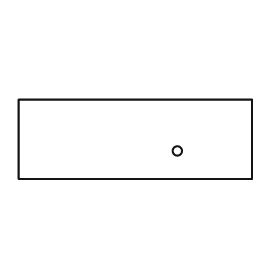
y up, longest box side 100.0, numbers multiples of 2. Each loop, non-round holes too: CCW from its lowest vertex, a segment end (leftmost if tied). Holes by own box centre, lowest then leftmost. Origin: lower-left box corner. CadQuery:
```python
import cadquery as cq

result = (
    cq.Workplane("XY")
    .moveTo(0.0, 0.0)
    .lineTo(100.0, 0.0)
    .lineTo(100.0, 34.0)
    .lineTo(0.0, 34.0)
    .close()
    .moveTo(68.0, 12.0)
    .circle(2.0)
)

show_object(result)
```